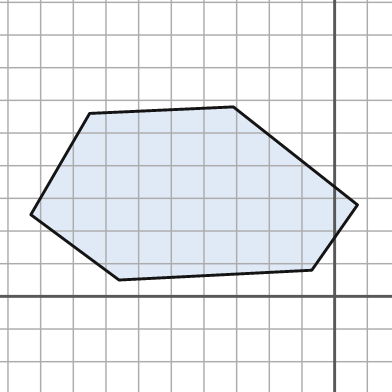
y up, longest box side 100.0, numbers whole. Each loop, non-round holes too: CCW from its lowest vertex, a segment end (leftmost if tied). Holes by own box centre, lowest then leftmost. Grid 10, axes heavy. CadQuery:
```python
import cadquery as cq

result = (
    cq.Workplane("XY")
    .moveTo(-66.0, 5.0)
    .lineTo(-7.0, 8.0)
    .lineTo(7.0, 28.0)
    .lineTo(-31.0, 58.0)
    .lineTo(-75.0, 56.0)
    .lineTo(-93.0, 25.0)
    .close()
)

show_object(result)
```